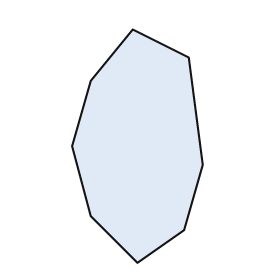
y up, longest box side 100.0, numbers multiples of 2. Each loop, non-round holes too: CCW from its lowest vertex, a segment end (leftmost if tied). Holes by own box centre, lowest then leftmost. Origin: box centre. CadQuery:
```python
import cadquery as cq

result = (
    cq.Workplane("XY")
    .moveTo(0.0, -50.0)
    .lineTo(20.0, -36.0)
    .lineTo(28.0, -8.0)
    .lineTo(22.0, 38.0)
    .lineTo(-2.0, 50.0)
    .lineTo(-20.0, 28.0)
    .lineTo(-28.0, 0.0)
    .lineTo(-20.0, -30.0)
    .close()
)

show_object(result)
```